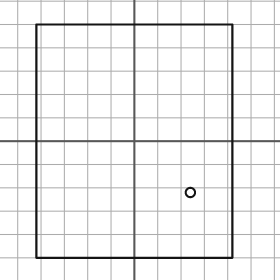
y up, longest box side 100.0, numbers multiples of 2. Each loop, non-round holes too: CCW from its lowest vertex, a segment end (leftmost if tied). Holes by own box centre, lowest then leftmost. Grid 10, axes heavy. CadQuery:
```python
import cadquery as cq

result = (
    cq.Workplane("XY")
    .moveTo(-42.0, -50.0)
    .lineTo(42.0, -50.0)
    .lineTo(42.0, 50.0)
    .lineTo(-42.0, 50.0)
    .close()
    .moveTo(24.0, -22.0)
    .circle(2.0)
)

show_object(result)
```